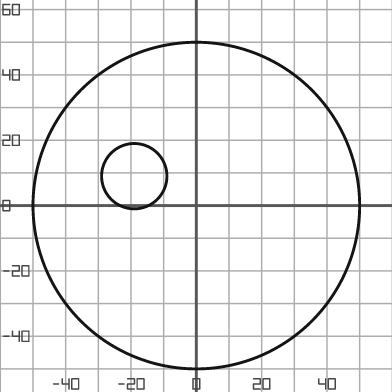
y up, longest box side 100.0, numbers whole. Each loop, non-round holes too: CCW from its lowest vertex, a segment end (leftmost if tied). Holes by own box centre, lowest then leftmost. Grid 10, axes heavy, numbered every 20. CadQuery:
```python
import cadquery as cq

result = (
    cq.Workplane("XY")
    .moveTo(0.0, 0.0)
    .circle(50.0)
    .moveTo(-19.0, 9.0)
    .circle(10.0)
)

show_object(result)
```